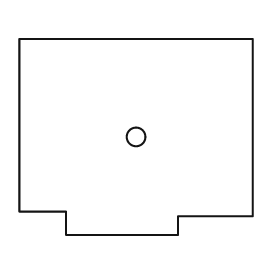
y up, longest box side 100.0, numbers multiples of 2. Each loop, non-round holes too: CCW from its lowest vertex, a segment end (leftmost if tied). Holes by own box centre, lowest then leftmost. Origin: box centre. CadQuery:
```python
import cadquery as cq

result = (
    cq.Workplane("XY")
    .moveTo(-30.0, -42.0)
    .lineTo(18.0, -42.0)
    .lineTo(18.0, -34.0)
    .lineTo(50.0, -34.0)
    .lineTo(50.0, 42.0)
    .lineTo(-50.0, 42.0)
    .lineTo(-50.0, -32.0)
    .lineTo(-30.0, -32.0)
    .close()
    .moveTo(0.0, 0.0)
    .circle(4.0)
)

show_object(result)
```